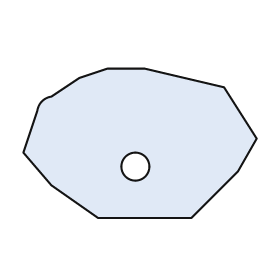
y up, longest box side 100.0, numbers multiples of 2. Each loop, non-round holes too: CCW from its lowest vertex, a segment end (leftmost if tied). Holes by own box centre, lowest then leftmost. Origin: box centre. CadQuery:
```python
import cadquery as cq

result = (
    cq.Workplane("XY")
    .moveTo(-18.0, -32.0)
    .lineTo(22.0, -32.0)
    .lineTo(42.0, -12.0)
    .lineTo(50.0, 2.0)
    .lineTo(36.0, 24.0)
    .lineTo(2.0, 32.0)
    .lineTo(-14.0, 32.0)
    .lineTo(-26.0, 28.0)
    .lineTo(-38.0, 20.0)
    .threePointArc((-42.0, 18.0), (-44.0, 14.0))
    .lineTo(-50.0, -4.0)
    .lineTo(-38.0, -18.0)
    .close()
    .moveTo(-2.0, -10.0)
    .circle(6.0)
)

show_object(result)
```